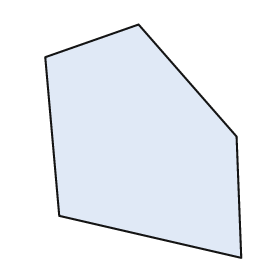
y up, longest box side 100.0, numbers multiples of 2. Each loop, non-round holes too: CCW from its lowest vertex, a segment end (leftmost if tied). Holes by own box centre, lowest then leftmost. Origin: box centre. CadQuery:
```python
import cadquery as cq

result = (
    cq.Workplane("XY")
    .moveTo(42.0, -50.0)
    .lineTo(40.0, 2.0)
    .lineTo(-2.0, 50.0)
    .lineTo(-42.0, 36.0)
    .lineTo(-36.0, -32.0)
    .close()
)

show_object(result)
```